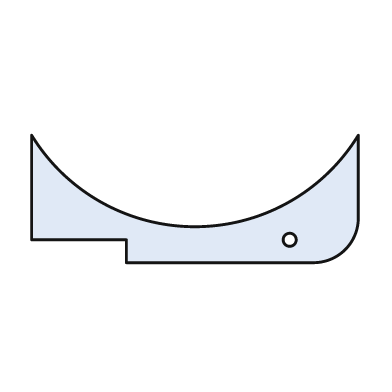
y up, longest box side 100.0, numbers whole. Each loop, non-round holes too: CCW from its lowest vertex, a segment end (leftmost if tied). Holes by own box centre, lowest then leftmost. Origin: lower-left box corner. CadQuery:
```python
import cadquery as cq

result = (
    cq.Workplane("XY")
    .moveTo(29.0, 0.0)
    .lineTo(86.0, 0.0)
    .threePointArc((96.0, 4.0), (100.0, 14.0))
    .lineTo(100.0, 39.0)
    .threePointArc((50.0, 11.0), (0.0, 39.0))
    .lineTo(0.0, 7.0)
    .lineTo(29.0, 7.0)
    .close()
    .moveTo(79.0, 7.0)
    .circle(2.0)
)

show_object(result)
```